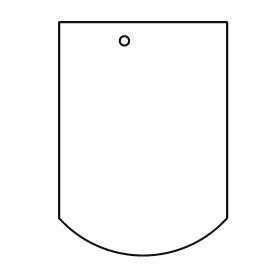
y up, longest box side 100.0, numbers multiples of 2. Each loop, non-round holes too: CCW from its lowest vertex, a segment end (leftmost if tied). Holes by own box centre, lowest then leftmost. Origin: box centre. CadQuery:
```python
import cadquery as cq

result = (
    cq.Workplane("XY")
    .moveTo(-36.0, -34.0)
    .threePointArc((0.0, -50.0), (36.0, -34.0))
    .lineTo(36.0, 50.0)
    .lineTo(-36.0, 50.0)
    .close()
    .moveTo(-8.0, 42.0)
    .circle(2.0)
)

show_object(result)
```